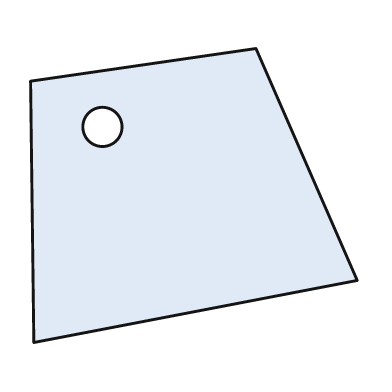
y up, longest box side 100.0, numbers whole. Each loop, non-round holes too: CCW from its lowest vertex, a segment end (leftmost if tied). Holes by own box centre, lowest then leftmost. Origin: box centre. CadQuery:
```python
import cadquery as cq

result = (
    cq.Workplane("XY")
    .moveTo(-49.0, -45.0)
    .lineTo(50.0, -26.0)
    .lineTo(19.0, 45.0)
    .lineTo(-50.0, 35.0)
    .close()
    .moveTo(-28.0, 21.0)
    .circle(6.0)
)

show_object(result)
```